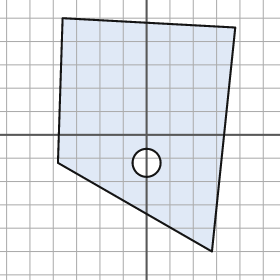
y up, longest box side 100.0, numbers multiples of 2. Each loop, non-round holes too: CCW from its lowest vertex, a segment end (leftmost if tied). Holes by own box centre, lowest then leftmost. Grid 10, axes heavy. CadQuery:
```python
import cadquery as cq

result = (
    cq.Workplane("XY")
    .moveTo(28.0, -50.0)
    .lineTo(38.0, 46.0)
    .lineTo(-36.0, 50.0)
    .lineTo(-38.0, -12.0)
    .close()
    .moveTo(0.0, -12.0)
    .circle(6.0)
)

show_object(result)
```